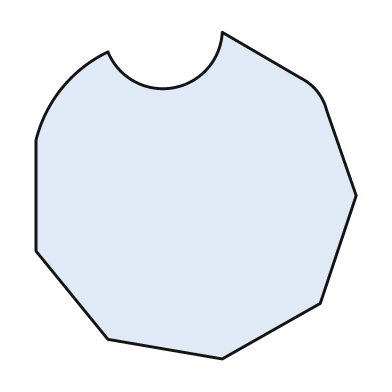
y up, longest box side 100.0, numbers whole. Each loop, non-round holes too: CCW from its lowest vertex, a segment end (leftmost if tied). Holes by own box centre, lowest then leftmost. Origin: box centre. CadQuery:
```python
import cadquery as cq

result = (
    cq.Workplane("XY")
    .moveTo(8.0, -50.0)
    .lineTo(38.0, -33.0)
    .lineTo(49.0, 0.0)
    .lineTo(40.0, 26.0)
    .threePointArc((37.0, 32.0), (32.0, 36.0))
    .lineTo(8.0, 50.0)
    .threePointArc((-7.0, 33.0), (-27.0, 44.0))
    .threePointArc((-41.0, 33.0), (-49.0, 17.0))
    .lineTo(-49.0, -17.0)
    .lineTo(-27.0, -44.0)
    .close()
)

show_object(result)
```